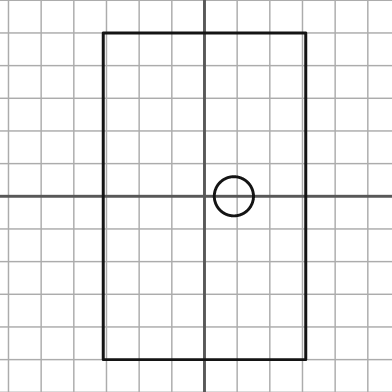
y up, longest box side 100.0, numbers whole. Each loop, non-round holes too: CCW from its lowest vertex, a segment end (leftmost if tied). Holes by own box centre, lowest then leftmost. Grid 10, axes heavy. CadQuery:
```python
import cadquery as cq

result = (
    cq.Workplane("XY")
    .moveTo(-31.0, -50.0)
    .lineTo(31.0, -50.0)
    .lineTo(31.0, 50.0)
    .lineTo(-31.0, 50.0)
    .close()
    .moveTo(9.0, 0.0)
    .circle(6.0)
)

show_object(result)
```